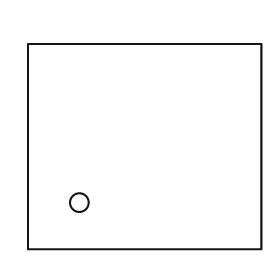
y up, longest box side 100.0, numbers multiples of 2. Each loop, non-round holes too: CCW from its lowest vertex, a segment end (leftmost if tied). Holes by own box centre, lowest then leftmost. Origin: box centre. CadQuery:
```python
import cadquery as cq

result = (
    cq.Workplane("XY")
    .moveTo(-50.0, -44.0)
    .lineTo(50.0, -44.0)
    .lineTo(50.0, 44.0)
    .lineTo(-50.0, 44.0)
    .close()
    .moveTo(-28.0, -24.0)
    .circle(4.0)
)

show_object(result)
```